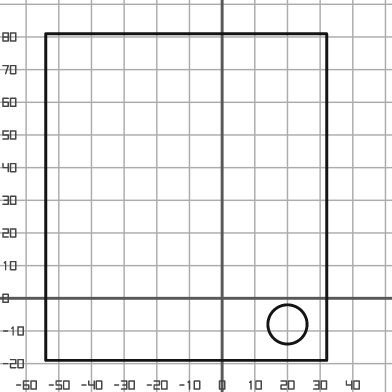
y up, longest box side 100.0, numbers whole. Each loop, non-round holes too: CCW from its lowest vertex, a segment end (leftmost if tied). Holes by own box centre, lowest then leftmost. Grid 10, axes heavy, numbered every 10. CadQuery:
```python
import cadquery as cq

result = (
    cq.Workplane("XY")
    .moveTo(-54.0, -19.0)
    .lineTo(32.0, -19.0)
    .lineTo(32.0, 81.0)
    .lineTo(-54.0, 81.0)
    .close()
    .moveTo(20.0, -8.0)
    .circle(6.0)
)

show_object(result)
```